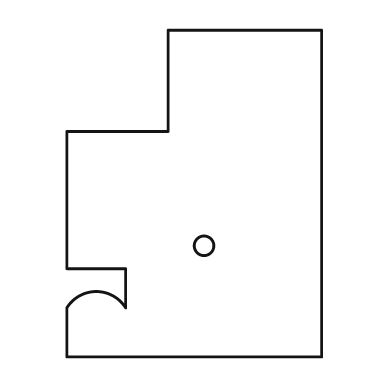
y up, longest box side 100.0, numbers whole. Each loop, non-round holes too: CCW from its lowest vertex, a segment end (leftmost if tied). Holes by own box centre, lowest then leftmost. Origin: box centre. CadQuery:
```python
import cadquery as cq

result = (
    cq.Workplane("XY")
    .moveTo(-39.0, -50.0)
    .lineTo(39.0, -50.0)
    .lineTo(39.0, 50.0)
    .lineTo(-8.0, 50.0)
    .lineTo(-8.0, 19.0)
    .lineTo(-39.0, 19.0)
    .lineTo(-39.0, -23.0)
    .lineTo(-21.0, -23.0)
    .lineTo(-21.0, -35.0)
    .threePointArc((-30.0, -30.0), (-39.0, -35.0))
    .close()
    .moveTo(3.0, -16.0)
    .circle(3.0)
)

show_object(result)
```